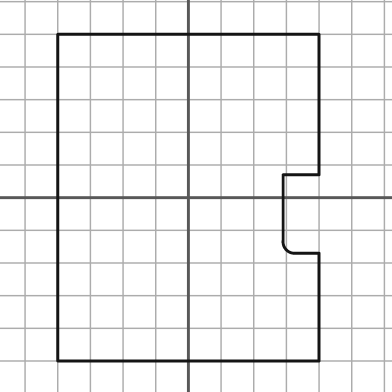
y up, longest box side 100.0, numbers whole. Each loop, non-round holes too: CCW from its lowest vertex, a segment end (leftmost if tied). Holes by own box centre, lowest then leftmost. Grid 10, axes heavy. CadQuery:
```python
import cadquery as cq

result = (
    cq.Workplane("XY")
    .moveTo(-40.0, -50.0)
    .lineTo(40.0, -50.0)
    .lineTo(40.0, -17.0)
    .lineTo(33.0, -17.0)
    .threePointArc((30.0, -16.0), (29.0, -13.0))
    .lineTo(29.0, 7.0)
    .lineTo(40.0, 7.0)
    .lineTo(40.0, 50.0)
    .lineTo(-40.0, 50.0)
    .close()
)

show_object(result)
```